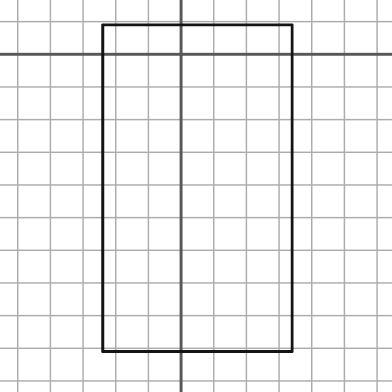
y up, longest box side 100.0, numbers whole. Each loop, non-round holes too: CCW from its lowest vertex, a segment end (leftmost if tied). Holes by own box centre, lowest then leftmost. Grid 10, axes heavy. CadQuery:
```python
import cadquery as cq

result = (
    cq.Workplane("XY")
    .moveTo(-24.0, -91.0)
    .lineTo(34.0, -91.0)
    .lineTo(34.0, 9.0)
    .lineTo(-24.0, 9.0)
    .close()
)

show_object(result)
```